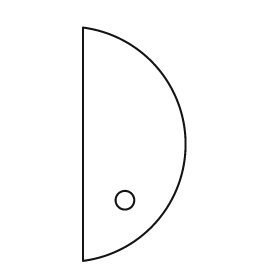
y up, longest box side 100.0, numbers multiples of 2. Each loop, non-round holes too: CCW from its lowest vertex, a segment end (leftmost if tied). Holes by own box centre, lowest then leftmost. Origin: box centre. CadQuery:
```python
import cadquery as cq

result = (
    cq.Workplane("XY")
    .moveTo(-22.0, -50.0)
    .threePointArc((22.0, 0.0), (-22.0, 50.0))
    .close()
    .moveTo(-4.0, -24.0)
    .circle(4.0)
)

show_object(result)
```